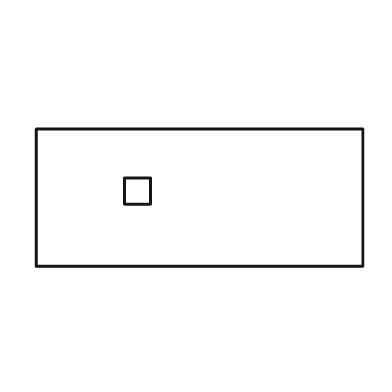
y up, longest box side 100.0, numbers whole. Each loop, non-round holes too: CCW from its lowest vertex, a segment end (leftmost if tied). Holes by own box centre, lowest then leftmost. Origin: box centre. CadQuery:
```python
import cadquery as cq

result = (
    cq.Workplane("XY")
    .moveTo(-50.0, -21.0)
    .lineTo(50.0, -21.0)
    .lineTo(50.0, 21.0)
    .lineTo(-50.0, 21.0)
    .close()
    .moveTo(-23.0, -2.0)
    .lineTo(-15.0, -2.0)
    .lineTo(-15.0, 6.0)
    .lineTo(-23.0, 6.0)
    .close()
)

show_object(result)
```